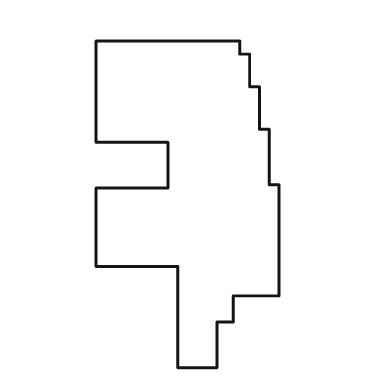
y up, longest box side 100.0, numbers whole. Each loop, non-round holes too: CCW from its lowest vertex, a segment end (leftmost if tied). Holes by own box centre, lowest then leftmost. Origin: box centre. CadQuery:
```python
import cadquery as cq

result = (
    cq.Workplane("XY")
    .moveTo(-3.0, -50.0)
    .lineTo(9.0, -50.0)
    .lineTo(9.0, -36.0)
    .lineTo(14.0, -36.0)
    .lineTo(14.0, -28.0)
    .lineTo(28.0, -28.0)
    .lineTo(28.0, 6.0)
    .lineTo(25.0, 6.0)
    .lineTo(25.0, 23.0)
    .lineTo(22.0, 23.0)
    .lineTo(22.0, 36.0)
    .lineTo(19.0, 36.0)
    .lineTo(19.0, 46.0)
    .lineTo(16.0, 46.0)
    .lineTo(16.0, 50.0)
    .lineTo(-28.0, 50.0)
    .lineTo(-28.0, 19.0)
    .lineTo(-6.0, 19.0)
    .lineTo(-6.0, 5.0)
    .lineTo(-28.0, 5.0)
    .lineTo(-28.0, -19.0)
    .lineTo(-3.0, -19.0)
    .close()
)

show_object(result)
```